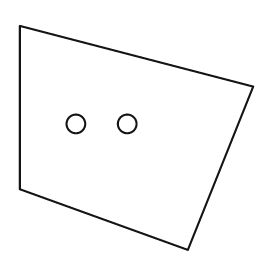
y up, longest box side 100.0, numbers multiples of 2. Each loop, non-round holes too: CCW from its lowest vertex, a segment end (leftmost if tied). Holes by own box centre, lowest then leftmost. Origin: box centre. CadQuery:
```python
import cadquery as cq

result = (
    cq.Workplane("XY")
    .moveTo(22.0, -48.0)
    .lineTo(50.0, 22.0)
    .lineTo(-50.0, 48.0)
    .lineTo(-50.0, -22.0)
    .close()
    .moveTo(-26.0, 6.0)
    .circle(4.0)
    .moveTo(-4.0, 6.0)
    .circle(4.0)
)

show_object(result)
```